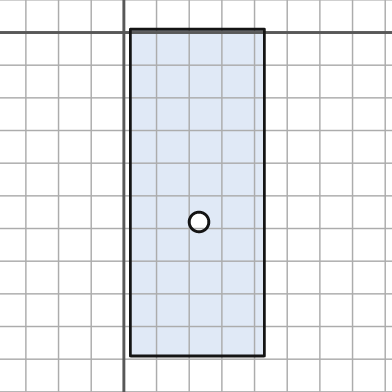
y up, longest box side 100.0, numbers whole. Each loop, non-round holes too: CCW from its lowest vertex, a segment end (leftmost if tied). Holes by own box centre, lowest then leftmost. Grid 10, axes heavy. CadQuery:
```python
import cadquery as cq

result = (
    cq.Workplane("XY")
    .moveTo(2.0, -99.0)
    .lineTo(43.0, -99.0)
    .lineTo(43.0, 1.0)
    .lineTo(2.0, 1.0)
    .close()
    .moveTo(23.0, -58.0)
    .circle(3.0)
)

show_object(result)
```